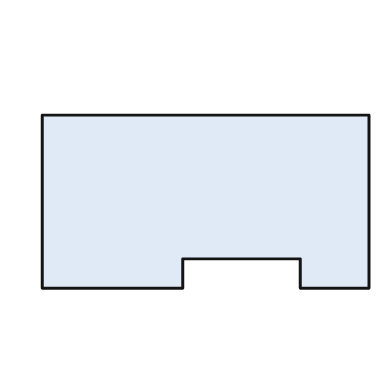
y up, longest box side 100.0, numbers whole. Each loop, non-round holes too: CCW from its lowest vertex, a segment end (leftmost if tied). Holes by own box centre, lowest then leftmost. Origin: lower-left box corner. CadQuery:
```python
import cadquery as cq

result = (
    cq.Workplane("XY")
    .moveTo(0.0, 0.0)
    .lineTo(43.0, 0.0)
    .lineTo(43.0, 9.0)
    .lineTo(79.0, 9.0)
    .lineTo(79.0, 0.0)
    .lineTo(100.0, 0.0)
    .lineTo(100.0, 53.0)
    .lineTo(0.0, 53.0)
    .close()
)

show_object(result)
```